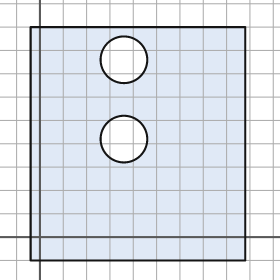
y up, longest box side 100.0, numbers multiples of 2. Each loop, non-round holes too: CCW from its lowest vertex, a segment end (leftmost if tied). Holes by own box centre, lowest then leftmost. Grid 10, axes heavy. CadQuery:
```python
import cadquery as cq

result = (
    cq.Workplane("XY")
    .moveTo(-4.0, -10.0)
    .lineTo(88.0, -10.0)
    .lineTo(88.0, 90.0)
    .lineTo(-4.0, 90.0)
    .close()
    .moveTo(36.0, 42.0)
    .circle(10.0)
    .moveTo(36.0, 76.0)
    .circle(10.0)
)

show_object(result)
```